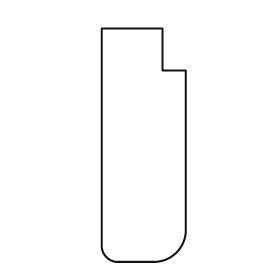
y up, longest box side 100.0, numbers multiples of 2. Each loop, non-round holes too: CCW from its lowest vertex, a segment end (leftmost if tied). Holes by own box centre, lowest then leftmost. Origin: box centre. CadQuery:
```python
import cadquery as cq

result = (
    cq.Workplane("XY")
    .moveTo(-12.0, -50.0)
    .lineTo(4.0, -50.0)
    .threePointArc((14.0, -46.0), (18.0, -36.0))
    .lineTo(18.0, 32.0)
    .lineTo(8.0, 32.0)
    .lineTo(8.0, 50.0)
    .lineTo(-18.0, 50.0)
    .lineTo(-18.0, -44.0)
    .threePointArc((-16.0, -48.0), (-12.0, -50.0))
    .close()
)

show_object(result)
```